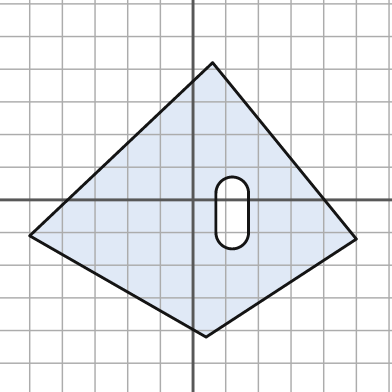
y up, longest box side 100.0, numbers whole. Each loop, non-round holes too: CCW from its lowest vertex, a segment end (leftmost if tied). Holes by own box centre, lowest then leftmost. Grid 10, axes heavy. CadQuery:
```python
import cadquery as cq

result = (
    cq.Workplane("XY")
    .moveTo(4.0, -42.0)
    .lineTo(50.0, -12.0)
    .lineTo(6.0, 42.0)
    .lineTo(-50.0, -11.0)
    .close()
    .moveTo(7.0, -10.0)
    .threePointArc((12.0, -15.0), (17.0, -10.0))
    .lineTo(17.0, 2.0)
    .threePointArc((12.0, 7.0), (7.0, 2.0))
    .close()
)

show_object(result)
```